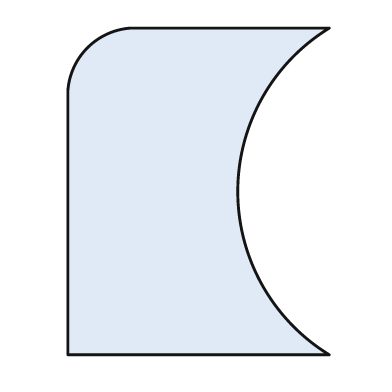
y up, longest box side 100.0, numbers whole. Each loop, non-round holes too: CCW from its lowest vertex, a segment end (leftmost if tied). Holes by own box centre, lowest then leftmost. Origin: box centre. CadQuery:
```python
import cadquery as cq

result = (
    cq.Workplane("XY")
    .moveTo(-40.0, -50.0)
    .lineTo(40.0, -50.0)
    .threePointArc((12.0, 0.0), (40.0, 50.0))
    .lineTo(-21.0, 50.0)
    .threePointArc((-34.0, 44.0), (-40.0, 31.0))
    .close()
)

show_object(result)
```